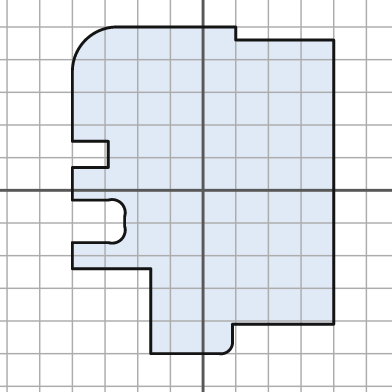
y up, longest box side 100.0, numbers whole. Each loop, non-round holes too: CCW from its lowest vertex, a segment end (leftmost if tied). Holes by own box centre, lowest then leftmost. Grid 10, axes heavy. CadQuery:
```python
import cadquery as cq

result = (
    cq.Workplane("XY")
    .moveTo(-16.0, -50.0)
    .lineTo(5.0, -50.0)
    .threePointArc((8.0, -49.0), (9.0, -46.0))
    .lineTo(9.0, -41.0)
    .lineTo(40.0, -41.0)
    .lineTo(40.0, 46.0)
    .lineTo(10.0, 46.0)
    .lineTo(10.0, 50.0)
    .lineTo(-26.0, 50.0)
    .threePointArc((-36.0, 46.0), (-40.0, 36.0))
    .lineTo(-40.0, 15.0)
    .lineTo(-29.0, 15.0)
    .lineTo(-29.0, 7.0)
    .lineTo(-40.0, 7.0)
    .lineTo(-40.0, -3.0)
    .lineTo(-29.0, -3.0)
    .threePointArc((-25.0, -4.0), (-24.0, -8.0))
    .lineTo(-24.0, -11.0)
    .threePointArc((-25.0, -15.0), (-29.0, -16.0))
    .lineTo(-40.0, -16.0)
    .lineTo(-40.0, -24.0)
    .lineTo(-16.0, -24.0)
    .close()
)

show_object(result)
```